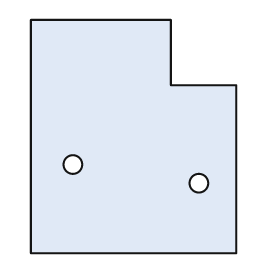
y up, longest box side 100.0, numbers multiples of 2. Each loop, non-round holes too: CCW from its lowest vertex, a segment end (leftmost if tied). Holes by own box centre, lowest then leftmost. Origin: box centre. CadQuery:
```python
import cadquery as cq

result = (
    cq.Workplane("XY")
    .moveTo(-44.0, -50.0)
    .lineTo(44.0, -50.0)
    .lineTo(44.0, 22.0)
    .lineTo(16.0, 22.0)
    .lineTo(16.0, 50.0)
    .lineTo(-44.0, 50.0)
    .close()
    .moveTo(28.0, -20.0)
    .circle(4.0)
    .moveTo(-26.0, -12.0)
    .circle(4.0)
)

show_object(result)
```